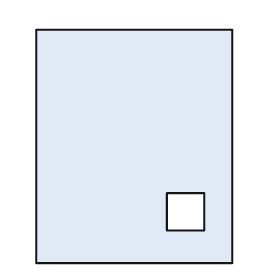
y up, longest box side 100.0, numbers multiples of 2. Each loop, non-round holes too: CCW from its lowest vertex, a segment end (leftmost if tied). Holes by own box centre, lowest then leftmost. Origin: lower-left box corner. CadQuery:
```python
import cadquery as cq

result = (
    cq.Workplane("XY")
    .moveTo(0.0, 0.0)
    .lineTo(84.0, 0.0)
    .lineTo(84.0, 100.0)
    .lineTo(0.0, 100.0)
    .close()
    .moveTo(56.0, 14.0)
    .lineTo(72.0, 14.0)
    .lineTo(72.0, 30.0)
    .lineTo(56.0, 30.0)
    .close()
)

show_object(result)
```